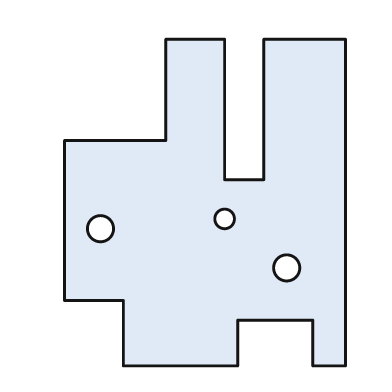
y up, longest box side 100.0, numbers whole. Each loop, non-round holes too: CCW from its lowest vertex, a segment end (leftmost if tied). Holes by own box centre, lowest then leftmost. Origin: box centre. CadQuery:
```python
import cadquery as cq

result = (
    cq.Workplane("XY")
    .moveTo(-25.0, -50.0)
    .lineTo(10.0, -50.0)
    .lineTo(10.0, -36.0)
    .lineTo(33.0, -36.0)
    .lineTo(33.0, -50.0)
    .lineTo(43.0, -50.0)
    .lineTo(43.0, 50.0)
    .lineTo(18.0, 50.0)
    .lineTo(18.0, 7.0)
    .lineTo(6.0, 7.0)
    .lineTo(6.0, 50.0)
    .lineTo(-12.0, 50.0)
    .lineTo(-12.0, 19.0)
    .lineTo(-43.0, 19.0)
    .lineTo(-43.0, -30.0)
    .lineTo(-25.0, -30.0)
    .close()
    .moveTo(25.0, -20.0)
    .circle(4.0)
    .moveTo(-32.0, -8.0)
    .circle(4.0)
    .moveTo(6.0, -5.0)
    .circle(3.0)
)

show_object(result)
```